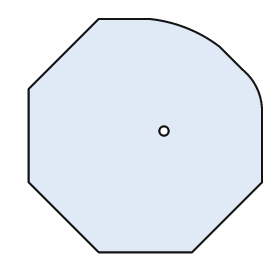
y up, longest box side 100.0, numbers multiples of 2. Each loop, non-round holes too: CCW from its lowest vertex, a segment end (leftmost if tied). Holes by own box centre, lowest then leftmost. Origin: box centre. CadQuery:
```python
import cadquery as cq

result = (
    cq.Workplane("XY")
    .moveTo(-20.0, -50.0)
    .lineTo(20.0, -50.0)
    .lineTo(50.0, -20.0)
    .lineTo(50.0, 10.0)
    .threePointArc((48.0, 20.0), (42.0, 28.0))
    .lineTo(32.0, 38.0)
    .threePointArc((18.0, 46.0), (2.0, 50.0))
    .lineTo(-20.0, 50.0)
    .lineTo(-50.0, 20.0)
    .lineTo(-50.0, -20.0)
    .close()
    .moveTo(8.0, 2.0)
    .circle(2.0)
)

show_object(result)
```